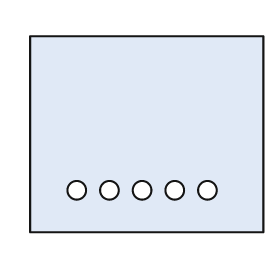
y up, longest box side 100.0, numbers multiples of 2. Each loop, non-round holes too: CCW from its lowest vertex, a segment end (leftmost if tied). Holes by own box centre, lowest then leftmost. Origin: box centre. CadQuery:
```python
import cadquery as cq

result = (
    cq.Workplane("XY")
    .moveTo(-50.0, -42.0)
    .lineTo(50.0, -42.0)
    .lineTo(50.0, 42.0)
    .lineTo(-50.0, 42.0)
    .close()
    .moveTo(-30.0, -24.0)
    .circle(4.0)
    .moveTo(-16.0, -24.0)
    .circle(4.0)
    .moveTo(-2.0, -24.0)
    .circle(4.0)
    .moveTo(12.0, -24.0)
    .circle(4.0)
    .moveTo(26.0, -24.0)
    .circle(4.0)
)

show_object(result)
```